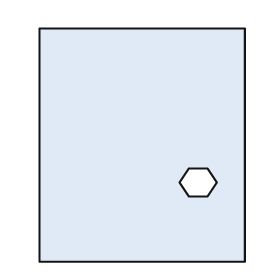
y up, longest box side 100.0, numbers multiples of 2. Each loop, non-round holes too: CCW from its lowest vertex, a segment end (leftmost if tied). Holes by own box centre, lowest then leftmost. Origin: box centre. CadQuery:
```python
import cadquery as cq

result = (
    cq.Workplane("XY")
    .moveTo(-44.0, -50.0)
    .lineTo(44.0, -50.0)
    .lineTo(44.0, 50.0)
    .lineTo(-44.0, 50.0)
    .close()
    .moveTo(20.0, -22.0)
    .lineTo(28.0, -22.0)
    .lineTo(32.0, -16.0)
    .lineTo(28.0, -10.0)
    .lineTo(20.0, -10.0)
    .lineTo(16.0, -16.0)
    .close()
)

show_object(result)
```